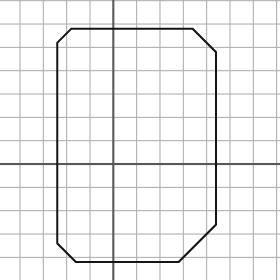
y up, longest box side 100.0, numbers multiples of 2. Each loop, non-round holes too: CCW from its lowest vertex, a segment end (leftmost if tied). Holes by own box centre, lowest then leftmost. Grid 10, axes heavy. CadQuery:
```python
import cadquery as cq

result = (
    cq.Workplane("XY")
    .moveTo(-16.0, -42.0)
    .lineTo(28.0, -42.0)
    .lineTo(44.0, -26.0)
    .lineTo(44.0, 48.0)
    .lineTo(34.0, 58.0)
    .lineTo(-18.0, 58.0)
    .lineTo(-24.0, 52.0)
    .lineTo(-24.0, -34.0)
    .close()
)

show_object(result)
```